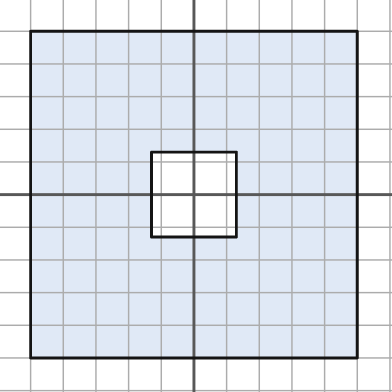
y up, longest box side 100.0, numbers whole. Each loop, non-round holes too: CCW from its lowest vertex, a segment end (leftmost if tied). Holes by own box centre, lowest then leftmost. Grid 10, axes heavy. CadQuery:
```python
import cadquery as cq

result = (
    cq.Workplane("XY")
    .moveTo(-50.0, -50.0)
    .lineTo(50.0, -50.0)
    .lineTo(50.0, 50.0)
    .lineTo(-50.0, 50.0)
    .close()
    .moveTo(-13.0, -13.0)
    .lineTo(13.0, -13.0)
    .lineTo(13.0, 13.0)
    .lineTo(-13.0, 13.0)
    .close()
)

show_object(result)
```